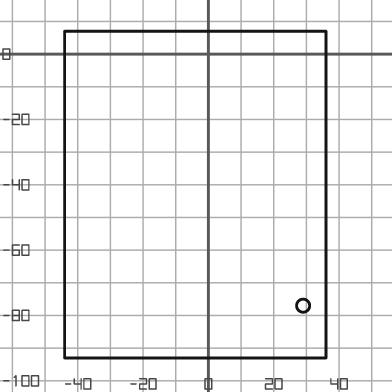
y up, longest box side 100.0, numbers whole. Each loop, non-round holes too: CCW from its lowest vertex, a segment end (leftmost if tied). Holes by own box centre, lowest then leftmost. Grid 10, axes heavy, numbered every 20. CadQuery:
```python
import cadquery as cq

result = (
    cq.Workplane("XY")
    .moveTo(-44.0, -93.0)
    .lineTo(36.0, -93.0)
    .lineTo(36.0, 7.0)
    .lineTo(-44.0, 7.0)
    .close()
    .moveTo(29.0, -77.0)
    .circle(2.0)
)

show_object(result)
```